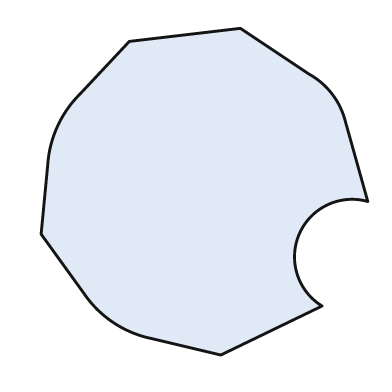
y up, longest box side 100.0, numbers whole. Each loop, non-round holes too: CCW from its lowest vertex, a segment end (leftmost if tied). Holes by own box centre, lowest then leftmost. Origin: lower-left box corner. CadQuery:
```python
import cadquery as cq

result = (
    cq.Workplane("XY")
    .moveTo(55.0, 0.0)
    .lineTo(86.0, 15.0)
    .threePointArc((79.0, 37.0), (100.0, 47.0))
    .lineTo(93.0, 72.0)
    .threePointArc((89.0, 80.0), (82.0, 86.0))
    .lineTo(61.0, 100.0)
    .lineTo(27.0, 96.0)
    .lineTo(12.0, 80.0)
    .threePointArc((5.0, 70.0), (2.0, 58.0))
    .lineTo(0.0, 37.0)
    .lineTo(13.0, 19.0)
    .threePointArc((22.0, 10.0), (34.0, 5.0))
    .close()
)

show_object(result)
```